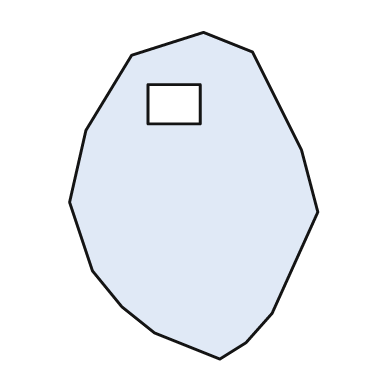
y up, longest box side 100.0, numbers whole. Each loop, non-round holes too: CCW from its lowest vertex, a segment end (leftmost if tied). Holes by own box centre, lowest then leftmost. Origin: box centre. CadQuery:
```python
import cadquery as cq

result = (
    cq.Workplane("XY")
    .moveTo(8.0, -50.0)
    .lineTo(16.0, -45.0)
    .lineTo(24.0, -36.0)
    .lineTo(38.0, -5.0)
    .lineTo(33.0, 14.0)
    .lineTo(18.0, 44.0)
    .lineTo(3.0, 50.0)
    .lineTo(-19.0, 43.0)
    .lineTo(-33.0, 20.0)
    .lineTo(-38.0, -2.0)
    .lineTo(-31.0, -23.0)
    .lineTo(-22.0, -34.0)
    .lineTo(-12.0, -42.0)
    .close()
    .moveTo(-14.0, 22.0)
    .lineTo(2.0, 22.0)
    .lineTo(2.0, 34.0)
    .lineTo(-14.0, 34.0)
    .close()
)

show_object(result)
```